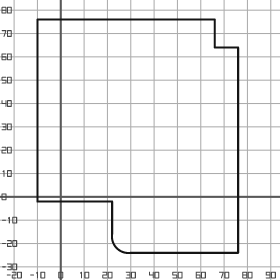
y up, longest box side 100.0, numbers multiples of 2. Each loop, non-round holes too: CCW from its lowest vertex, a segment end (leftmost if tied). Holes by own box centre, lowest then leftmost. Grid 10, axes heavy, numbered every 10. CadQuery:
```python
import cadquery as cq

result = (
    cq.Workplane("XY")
    .moveTo(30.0, -24.0)
    .lineTo(76.0, -24.0)
    .lineTo(76.0, 64.0)
    .lineTo(66.0, 64.0)
    .lineTo(66.0, 76.0)
    .lineTo(-10.0, 76.0)
    .lineTo(-10.0, -2.0)
    .lineTo(22.0, -2.0)
    .lineTo(22.0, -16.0)
    .threePointArc((24.0, -22.0), (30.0, -24.0))
    .close()
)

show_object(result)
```